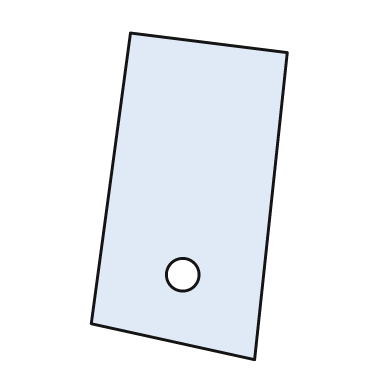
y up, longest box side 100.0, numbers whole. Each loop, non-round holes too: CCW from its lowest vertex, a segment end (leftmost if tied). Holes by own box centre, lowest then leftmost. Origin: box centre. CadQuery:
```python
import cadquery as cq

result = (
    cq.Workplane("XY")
    .moveTo(20.0, -50.0)
    .lineTo(30.0, 44.0)
    .lineTo(-18.0, 50.0)
    .lineTo(-30.0, -39.0)
    .close()
    .moveTo(-2.0, -24.0)
    .circle(5.0)
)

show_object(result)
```